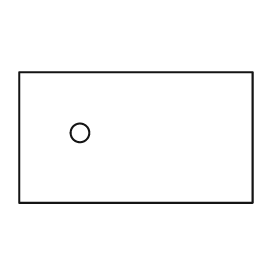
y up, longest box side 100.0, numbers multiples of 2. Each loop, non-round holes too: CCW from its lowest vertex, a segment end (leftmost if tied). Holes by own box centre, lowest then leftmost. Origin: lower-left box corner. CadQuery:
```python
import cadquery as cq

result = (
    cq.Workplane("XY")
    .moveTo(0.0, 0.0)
    .lineTo(100.0, 0.0)
    .lineTo(100.0, 56.0)
    .lineTo(0.0, 56.0)
    .close()
    .moveTo(26.0, 30.0)
    .circle(4.0)
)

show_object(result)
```